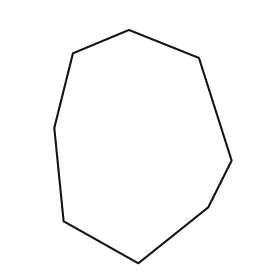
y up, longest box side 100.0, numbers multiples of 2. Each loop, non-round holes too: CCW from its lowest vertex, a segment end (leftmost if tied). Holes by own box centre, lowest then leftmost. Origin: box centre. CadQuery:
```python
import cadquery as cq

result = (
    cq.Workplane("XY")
    .moveTo(-2.0, -50.0)
    .lineTo(28.0, -26.0)
    .lineTo(38.0, -6.0)
    .lineTo(24.0, 38.0)
    .lineTo(-6.0, 50.0)
    .lineTo(-30.0, 40.0)
    .lineTo(-38.0, 8.0)
    .lineTo(-34.0, -32.0)
    .close()
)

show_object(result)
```